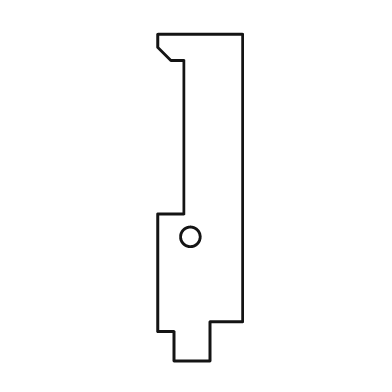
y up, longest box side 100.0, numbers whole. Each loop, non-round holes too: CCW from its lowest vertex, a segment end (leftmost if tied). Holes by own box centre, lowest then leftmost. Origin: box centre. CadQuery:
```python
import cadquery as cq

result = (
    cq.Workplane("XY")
    .moveTo(-8.0, -50.0)
    .lineTo(3.0, -50.0)
    .lineTo(3.0, -38.0)
    .lineTo(13.0, -38.0)
    .lineTo(13.0, 50.0)
    .lineTo(-13.0, 50.0)
    .lineTo(-13.0, 46.0)
    .lineTo(-9.0, 42.0)
    .lineTo(-5.0, 42.0)
    .lineTo(-5.0, -5.0)
    .lineTo(-13.0, -5.0)
    .lineTo(-13.0, -41.0)
    .lineTo(-8.0, -41.0)
    .close()
    .moveTo(-3.0, -12.0)
    .circle(3.0)
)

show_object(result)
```